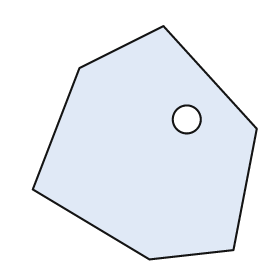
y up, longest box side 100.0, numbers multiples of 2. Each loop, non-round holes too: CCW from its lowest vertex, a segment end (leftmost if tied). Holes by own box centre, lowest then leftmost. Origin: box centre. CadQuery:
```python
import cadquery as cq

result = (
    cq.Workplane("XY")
    .moveTo(2.0, -50.0)
    .lineTo(38.0, -46.0)
    .lineTo(48.0, 6.0)
    .lineTo(8.0, 50.0)
    .lineTo(-28.0, 32.0)
    .lineTo(-48.0, -20.0)
    .close()
    .moveTo(18.0, 10.0)
    .circle(6.0)
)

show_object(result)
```